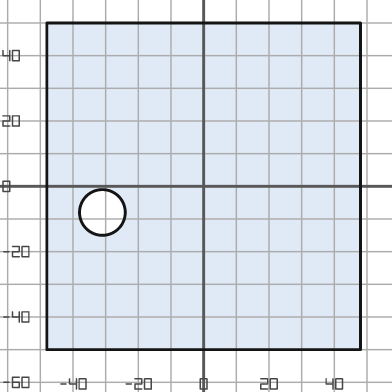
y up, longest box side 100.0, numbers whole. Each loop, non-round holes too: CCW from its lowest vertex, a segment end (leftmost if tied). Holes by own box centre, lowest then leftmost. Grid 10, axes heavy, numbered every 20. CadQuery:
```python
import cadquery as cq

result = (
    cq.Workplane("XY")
    .moveTo(-48.0, -50.0)
    .lineTo(48.0, -50.0)
    .lineTo(48.0, 50.0)
    .lineTo(-48.0, 50.0)
    .close()
    .moveTo(-31.0, -8.0)
    .circle(7.0)
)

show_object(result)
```